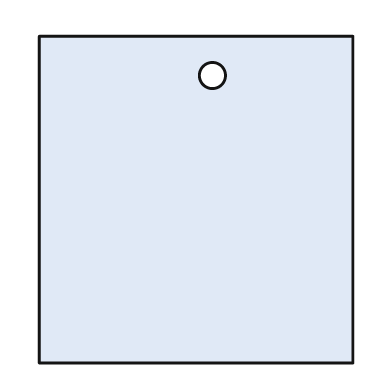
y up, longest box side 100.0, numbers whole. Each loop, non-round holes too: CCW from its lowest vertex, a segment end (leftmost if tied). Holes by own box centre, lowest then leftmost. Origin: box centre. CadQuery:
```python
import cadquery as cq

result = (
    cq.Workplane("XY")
    .moveTo(-48.0, -50.0)
    .lineTo(48.0, -50.0)
    .lineTo(48.0, 50.0)
    .lineTo(-48.0, 50.0)
    .close()
    .moveTo(5.0, 38.0)
    .circle(4.0)
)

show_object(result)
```